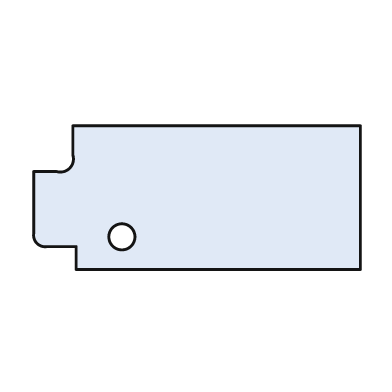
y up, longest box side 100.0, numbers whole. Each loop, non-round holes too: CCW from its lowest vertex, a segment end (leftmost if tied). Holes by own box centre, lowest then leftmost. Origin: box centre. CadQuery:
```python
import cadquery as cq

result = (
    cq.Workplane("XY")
    .moveTo(-37.0, -22.0)
    .lineTo(50.0, -22.0)
    .lineTo(50.0, 22.0)
    .lineTo(-38.0, 22.0)
    .lineTo(-38.0, 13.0)
    .threePointArc((-39.0, 9.0), (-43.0, 8.0))
    .lineTo(-50.0, 8.0)
    .lineTo(-50.0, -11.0)
    .threePointArc((-49.0, -14.0), (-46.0, -15.0))
    .lineTo(-37.0, -15.0)
    .close()
    .moveTo(-23.0, -12.0)
    .circle(4.0)
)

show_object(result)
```